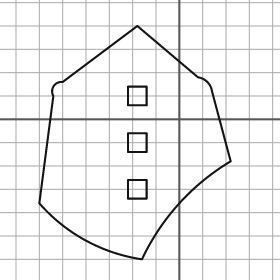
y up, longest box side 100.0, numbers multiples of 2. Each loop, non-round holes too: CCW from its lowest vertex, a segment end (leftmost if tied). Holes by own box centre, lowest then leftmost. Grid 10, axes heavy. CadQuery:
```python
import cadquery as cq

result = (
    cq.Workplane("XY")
    .moveTo(-16.0, -60.0)
    .threePointArc((0.0, -36.0), (22.0, -18.0))
    .lineTo(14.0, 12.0)
    .threePointArc((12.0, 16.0), (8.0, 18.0))
    .lineTo(-18.0, 40.0)
    .lineTo(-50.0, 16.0)
    .threePointArc((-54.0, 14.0), (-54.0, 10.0))
    .lineTo(-60.0, -36.0)
    .threePointArc((-40.0, -52.0), (-16.0, -60.0))
    .close()
    .moveTo(-22.0, -34.0)
    .lineTo(-14.0, -34.0)
    .lineTo(-14.0, -26.0)
    .lineTo(-22.0, -26.0)
    .close()
    .moveTo(-22.0, -14.0)
    .lineTo(-14.0, -14.0)
    .lineTo(-14.0, -6.0)
    .lineTo(-22.0, -6.0)
    .close()
    .moveTo(-22.0, 6.0)
    .lineTo(-14.0, 6.0)
    .lineTo(-14.0, 14.0)
    .lineTo(-22.0, 14.0)
    .close()
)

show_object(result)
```